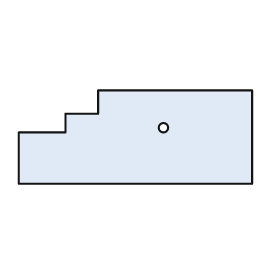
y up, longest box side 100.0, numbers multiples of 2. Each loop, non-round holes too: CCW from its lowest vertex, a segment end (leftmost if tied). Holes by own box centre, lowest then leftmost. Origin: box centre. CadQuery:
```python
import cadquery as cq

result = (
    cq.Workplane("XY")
    .moveTo(-50.0, -20.0)
    .lineTo(50.0, -20.0)
    .lineTo(50.0, 20.0)
    .lineTo(-16.0, 20.0)
    .lineTo(-16.0, 10.0)
    .lineTo(-30.0, 10.0)
    .lineTo(-30.0, 2.0)
    .lineTo(-50.0, 2.0)
    .close()
    .moveTo(12.0, 4.0)
    .circle(2.0)
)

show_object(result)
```